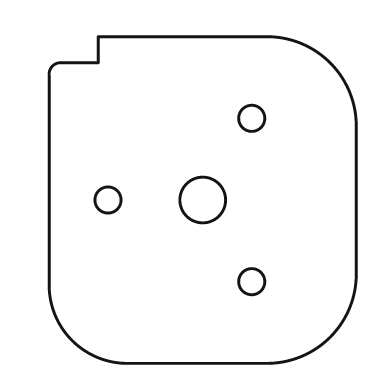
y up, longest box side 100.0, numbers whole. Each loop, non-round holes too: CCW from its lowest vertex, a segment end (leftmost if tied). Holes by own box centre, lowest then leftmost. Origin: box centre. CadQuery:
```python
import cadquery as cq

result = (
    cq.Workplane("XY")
    .moveTo(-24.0, -50.0)
    .lineTo(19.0, -50.0)
    .threePointArc((39.0, -42.0), (47.0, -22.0))
    .lineTo(47.0, 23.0)
    .threePointArc((39.0, 42.0), (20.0, 50.0))
    .lineTo(-32.0, 50.0)
    .lineTo(-32.0, 42.0)
    .lineTo(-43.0, 42.0)
    .threePointArc((-46.0, 41.0), (-47.0, 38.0))
    .lineTo(-47.0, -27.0)
    .threePointArc((-40.0, -43.0), (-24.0, -50.0))
    .close()
    .moveTo(15.0, -25.0)
    .circle(4.0)
    .moveTo(-29.0, 0.0)
    .circle(4.0)
    .moveTo(0.0, 0.0)
    .circle(7.0)
    .moveTo(15.0, 25.0)
    .circle(4.0)
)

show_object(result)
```